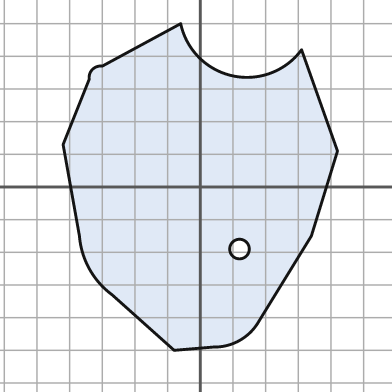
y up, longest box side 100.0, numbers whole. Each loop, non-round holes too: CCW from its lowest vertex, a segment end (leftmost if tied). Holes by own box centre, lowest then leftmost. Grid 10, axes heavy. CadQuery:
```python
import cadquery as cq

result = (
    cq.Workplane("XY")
    .moveTo(-8.0, -50.0)
    .lineTo(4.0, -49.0)
    .threePointArc((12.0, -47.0), (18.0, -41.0))
    .lineTo(34.0, -15.0)
    .lineTo(42.0, 11.0)
    .lineTo(31.0, 42.0)
    .threePointArc((10.0, 34.0), (-6.0, 50.0))
    .lineTo(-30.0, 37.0)
    .threePointArc((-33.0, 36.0), (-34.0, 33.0))
    .lineTo(-42.0, 13.0)
    .lineTo(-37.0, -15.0)
    .threePointArc((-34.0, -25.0), (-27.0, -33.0))
    .close()
    .moveTo(12.0, -19.0)
    .circle(3.0)
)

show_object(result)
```